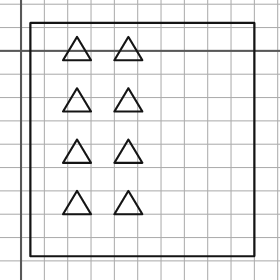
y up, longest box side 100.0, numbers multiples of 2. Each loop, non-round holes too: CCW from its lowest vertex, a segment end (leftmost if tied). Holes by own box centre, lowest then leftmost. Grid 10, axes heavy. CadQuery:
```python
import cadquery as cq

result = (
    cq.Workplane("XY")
    .moveTo(4.0, -88.0)
    .lineTo(100.0, -88.0)
    .lineTo(100.0, 12.0)
    .lineTo(4.0, 12.0)
    .close()
    .moveTo(18.0, -70.0)
    .lineTo(30.0, -70.0)
    .lineTo(24.0, -60.0)
    .close()
    .moveTo(40.0, -70.0)
    .lineTo(52.0, -70.0)
    .lineTo(46.0, -60.0)
    .close()
    .moveTo(18.0, -48.0)
    .lineTo(30.0, -48.0)
    .lineTo(24.0, -38.0)
    .close()
    .moveTo(40.0, -48.0)
    .lineTo(52.0, -48.0)
    .lineTo(46.0, -38.0)
    .close()
    .moveTo(18.0, -26.0)
    .lineTo(30.0, -26.0)
    .lineTo(24.0, -16.0)
    .close()
    .moveTo(40.0, -26.0)
    .lineTo(52.0, -26.0)
    .lineTo(46.0, -16.0)
    .close()
    .moveTo(18.0, -4.0)
    .lineTo(30.0, -4.0)
    .lineTo(24.0, 6.0)
    .close()
    .moveTo(40.0, -4.0)
    .lineTo(52.0, -4.0)
    .lineTo(46.0, 6.0)
    .close()
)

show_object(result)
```